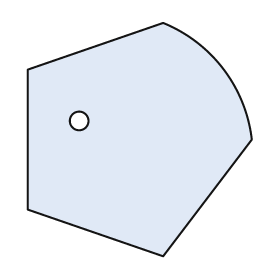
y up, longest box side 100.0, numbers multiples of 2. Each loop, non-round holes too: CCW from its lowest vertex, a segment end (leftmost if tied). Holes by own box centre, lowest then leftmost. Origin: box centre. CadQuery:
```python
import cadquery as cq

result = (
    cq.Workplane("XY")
    .moveTo(10.0, -50.0)
    .lineTo(48.0, 0.0)
    .threePointArc((36.0, 30.0), (10.0, 50.0))
    .lineTo(-48.0, 30.0)
    .lineTo(-48.0, -30.0)
    .close()
    .moveTo(-26.0, 8.0)
    .circle(4.0)
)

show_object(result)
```